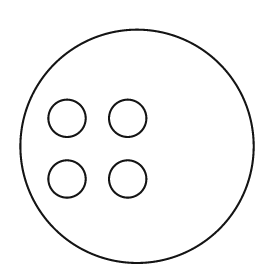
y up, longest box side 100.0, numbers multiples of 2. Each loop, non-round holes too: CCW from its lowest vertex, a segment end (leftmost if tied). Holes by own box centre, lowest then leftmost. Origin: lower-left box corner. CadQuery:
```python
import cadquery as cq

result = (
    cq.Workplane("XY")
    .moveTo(50.0, 50.0)
    .circle(50.0)
    .moveTo(20.0, 36.0)
    .circle(8.0)
    .moveTo(46.0, 36.0)
    .circle(8.0)
    .moveTo(20.0, 62.0)
    .circle(8.0)
    .moveTo(46.0, 62.0)
    .circle(8.0)
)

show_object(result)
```